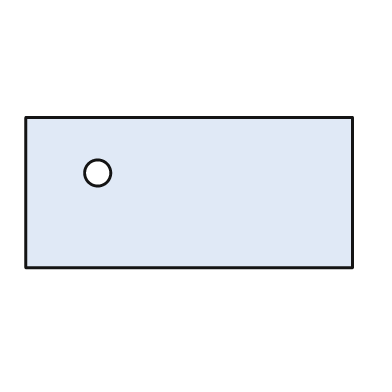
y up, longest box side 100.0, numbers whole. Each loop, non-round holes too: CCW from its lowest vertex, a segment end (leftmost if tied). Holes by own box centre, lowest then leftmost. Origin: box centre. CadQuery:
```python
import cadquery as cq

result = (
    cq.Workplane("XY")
    .moveTo(-50.0, -23.0)
    .lineTo(50.0, -23.0)
    .lineTo(50.0, 23.0)
    .lineTo(-50.0, 23.0)
    .close()
    .moveTo(-28.0, 6.0)
    .circle(4.0)
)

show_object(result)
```